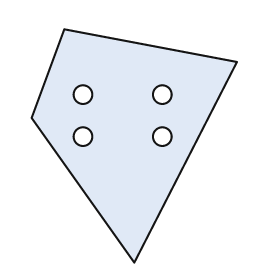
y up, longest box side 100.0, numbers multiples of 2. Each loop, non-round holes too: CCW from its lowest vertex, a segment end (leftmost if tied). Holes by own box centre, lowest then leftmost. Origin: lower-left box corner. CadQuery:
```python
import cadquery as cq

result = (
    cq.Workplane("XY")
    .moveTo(44.0, 0.0)
    .lineTo(88.0, 86.0)
    .lineTo(14.0, 100.0)
    .lineTo(0.0, 62.0)
    .close()
    .moveTo(22.0, 54.0)
    .circle(4.0)
    .moveTo(56.0, 54.0)
    .circle(4.0)
    .moveTo(22.0, 72.0)
    .circle(4.0)
    .moveTo(56.0, 72.0)
    .circle(4.0)
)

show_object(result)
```